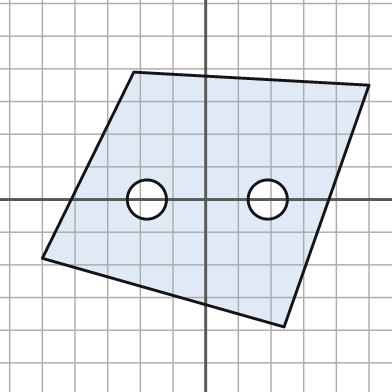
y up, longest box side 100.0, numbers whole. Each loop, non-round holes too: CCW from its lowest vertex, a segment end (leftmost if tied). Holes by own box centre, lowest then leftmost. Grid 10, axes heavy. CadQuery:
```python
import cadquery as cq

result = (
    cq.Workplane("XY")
    .moveTo(24.0, -39.0)
    .lineTo(50.0, 35.0)
    .lineTo(-22.0, 39.0)
    .lineTo(-50.0, -18.0)
    .close()
    .moveTo(-18.0, 0.0)
    .circle(6.0)
    .moveTo(19.0, 0.0)
    .circle(6.0)
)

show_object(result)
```